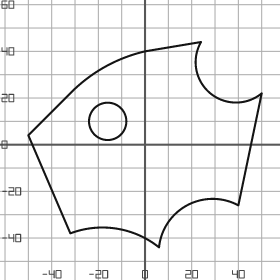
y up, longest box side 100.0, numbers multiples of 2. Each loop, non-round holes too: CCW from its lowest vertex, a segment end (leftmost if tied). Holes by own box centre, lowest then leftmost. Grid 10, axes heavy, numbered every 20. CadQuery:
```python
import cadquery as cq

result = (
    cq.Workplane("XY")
    .moveTo(6.0, -44.0)
    .threePointArc((18.0, -26.0), (40.0, -26.0))
    .lineTo(50.0, 22.0)
    .threePointArc((28.0, 22.0), (24.0, 44.0))
    .lineTo(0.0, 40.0)
    .threePointArc((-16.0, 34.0), (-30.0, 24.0))
    .lineTo(-50.0, 4.0)
    .lineTo(-32.0, -38.0)
    .threePointArc((-12.0, -36.0), (6.0, -44.0))
    .close()
    .moveTo(-16.0, 10.0)
    .circle(8.0)
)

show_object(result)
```